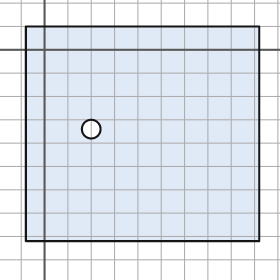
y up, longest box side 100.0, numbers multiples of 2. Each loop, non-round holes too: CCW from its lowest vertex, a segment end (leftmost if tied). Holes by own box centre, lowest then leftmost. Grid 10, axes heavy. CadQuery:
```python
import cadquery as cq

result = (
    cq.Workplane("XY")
    .moveTo(-8.0, -82.0)
    .lineTo(92.0, -82.0)
    .lineTo(92.0, 10.0)
    .lineTo(-8.0, 10.0)
    .close()
    .moveTo(20.0, -34.0)
    .circle(4.0)
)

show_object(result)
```